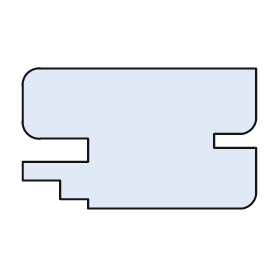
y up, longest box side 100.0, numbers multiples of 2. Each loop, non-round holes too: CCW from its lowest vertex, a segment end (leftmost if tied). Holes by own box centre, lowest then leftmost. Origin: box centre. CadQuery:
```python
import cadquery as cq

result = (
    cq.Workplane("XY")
    .moveTo(-22.0, -30.0)
    .lineTo(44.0, -30.0)
    .threePointArc((48.0, -28.0), (50.0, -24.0))
    .lineTo(50.0, -4.0)
    .lineTo(32.0, -4.0)
    .lineTo(32.0, 2.0)
    .lineTo(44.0, 2.0)
    .threePointArc((48.0, 4.0), (50.0, 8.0))
    .lineTo(50.0, 30.0)
    .lineTo(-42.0, 30.0)
    .threePointArc((-48.0, 28.0), (-50.0, 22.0))
    .lineTo(-50.0, 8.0)
    .threePointArc((-48.0, 2.0), (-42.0, 0.0))
    .lineTo(-22.0, 0.0)
    .lineTo(-22.0, -10.0)
    .lineTo(-50.0, -10.0)
    .lineTo(-50.0, -18.0)
    .lineTo(-34.0, -18.0)
    .lineTo(-34.0, -26.0)
    .lineTo(-22.0, -26.0)
    .close()
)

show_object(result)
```